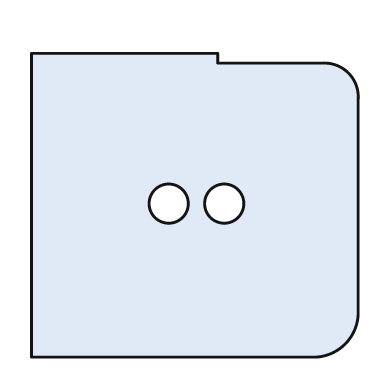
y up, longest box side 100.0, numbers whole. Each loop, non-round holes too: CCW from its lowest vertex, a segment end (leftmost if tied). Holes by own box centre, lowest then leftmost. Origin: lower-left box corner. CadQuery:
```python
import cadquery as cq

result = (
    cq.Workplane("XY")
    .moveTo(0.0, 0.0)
    .lineTo(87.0, 0.0)
    .threePointArc((96.0, 4.0), (100.0, 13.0))
    .lineTo(100.0, 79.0)
    .threePointArc((97.0, 87.0), (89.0, 90.0))
    .lineTo(57.0, 90.0)
    .lineTo(57.0, 93.0)
    .lineTo(0.0, 93.0)
    .close()
    .moveTo(42.0, 47.0)
    .circle(6.0)
    .moveTo(59.0, 47.0)
    .circle(6.0)
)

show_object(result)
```